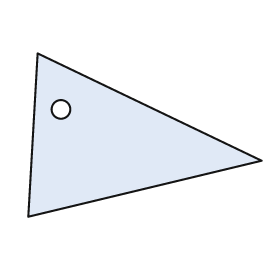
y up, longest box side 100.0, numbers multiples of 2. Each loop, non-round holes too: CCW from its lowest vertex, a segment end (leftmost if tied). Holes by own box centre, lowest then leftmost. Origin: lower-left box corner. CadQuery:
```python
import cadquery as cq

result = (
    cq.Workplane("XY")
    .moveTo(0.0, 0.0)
    .lineTo(100.0, 24.0)
    .lineTo(4.0, 70.0)
    .close()
    .moveTo(14.0, 46.0)
    .circle(4.0)
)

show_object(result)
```